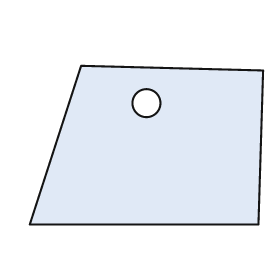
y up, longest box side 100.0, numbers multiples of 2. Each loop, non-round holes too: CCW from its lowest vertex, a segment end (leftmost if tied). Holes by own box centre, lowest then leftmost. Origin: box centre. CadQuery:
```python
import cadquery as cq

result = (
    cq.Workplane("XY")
    .moveTo(-50.0, -34.0)
    .lineTo(48.0, -34.0)
    .lineTo(50.0, 32.0)
    .lineTo(-28.0, 34.0)
    .close()
    .moveTo(0.0, 18.0)
    .circle(6.0)
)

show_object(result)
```